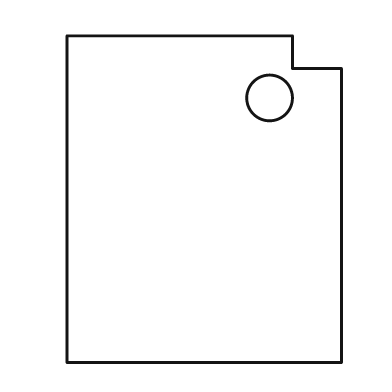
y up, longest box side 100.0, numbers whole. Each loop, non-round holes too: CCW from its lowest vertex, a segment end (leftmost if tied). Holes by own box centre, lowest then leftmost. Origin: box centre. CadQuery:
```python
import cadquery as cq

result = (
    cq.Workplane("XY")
    .moveTo(-42.0, -50.0)
    .lineTo(42.0, -50.0)
    .lineTo(42.0, 40.0)
    .lineTo(27.0, 40.0)
    .lineTo(27.0, 50.0)
    .lineTo(-42.0, 50.0)
    .close()
    .moveTo(20.0, 31.0)
    .circle(7.0)
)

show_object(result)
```